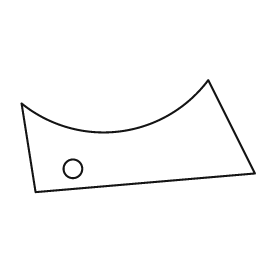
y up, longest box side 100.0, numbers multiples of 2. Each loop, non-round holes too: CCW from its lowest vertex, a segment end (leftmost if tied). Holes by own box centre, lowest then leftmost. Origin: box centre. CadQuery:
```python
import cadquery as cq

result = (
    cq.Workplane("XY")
    .moveTo(-44.0, -24.0)
    .lineTo(50.0, -16.0)
    .lineTo(30.0, 24.0)
    .threePointArc((-8.0, 2.0), (-50.0, 14.0))
    .close()
    .moveTo(-28.0, -14.0)
    .circle(4.0)
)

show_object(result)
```